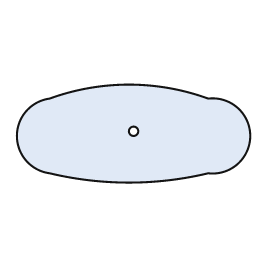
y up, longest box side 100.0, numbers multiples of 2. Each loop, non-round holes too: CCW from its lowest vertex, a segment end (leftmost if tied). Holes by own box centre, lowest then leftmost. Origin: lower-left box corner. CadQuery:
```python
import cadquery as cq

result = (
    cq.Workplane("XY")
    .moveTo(14.0, 4.0)
    .threePointArc((48.0, 0.0), (82.0, 4.0))
    .threePointArc((100.0, 20.0), (82.0, 36.0))
    .threePointArc((48.0, 42.0), (14.0, 36.0))
    .threePointArc((0.0, 20.0), (14.0, 4.0))
    .close()
    .moveTo(50.0, 22.0)
    .circle(2.0)
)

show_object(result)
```